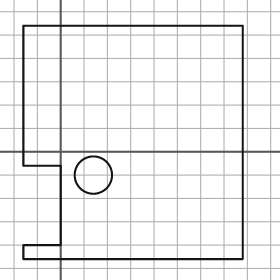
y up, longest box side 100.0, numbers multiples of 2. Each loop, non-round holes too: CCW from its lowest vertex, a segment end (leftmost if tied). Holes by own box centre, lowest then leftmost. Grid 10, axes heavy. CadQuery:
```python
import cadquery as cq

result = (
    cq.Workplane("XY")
    .moveTo(-16.0, -46.0)
    .lineTo(78.0, -46.0)
    .lineTo(78.0, 54.0)
    .lineTo(-16.0, 54.0)
    .lineTo(-16.0, -6.0)
    .lineTo(0.0, -6.0)
    .lineTo(0.0, -40.0)
    .lineTo(-16.0, -40.0)
    .close()
    .moveTo(14.0, -10.0)
    .circle(8.0)
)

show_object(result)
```